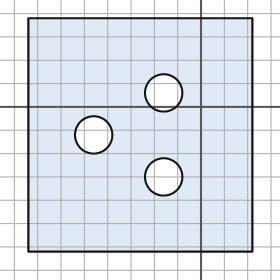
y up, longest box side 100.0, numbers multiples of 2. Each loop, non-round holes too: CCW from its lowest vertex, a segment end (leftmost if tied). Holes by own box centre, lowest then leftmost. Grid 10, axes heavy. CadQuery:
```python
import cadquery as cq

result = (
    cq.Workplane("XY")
    .moveTo(-74.0, -62.0)
    .lineTo(22.0, -62.0)
    .lineTo(22.0, 38.0)
    .lineTo(-74.0, 38.0)
    .close()
    .moveTo(-16.0, -30.0)
    .circle(8.0)
    .moveTo(-46.0, -12.0)
    .circle(8.0)
    .moveTo(-16.0, 6.0)
    .circle(8.0)
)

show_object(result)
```